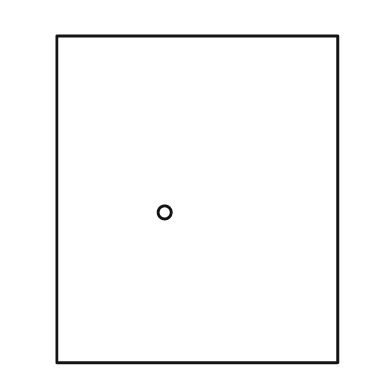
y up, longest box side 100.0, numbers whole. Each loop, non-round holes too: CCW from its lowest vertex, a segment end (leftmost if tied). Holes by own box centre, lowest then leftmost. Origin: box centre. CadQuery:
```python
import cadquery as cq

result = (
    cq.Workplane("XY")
    .moveTo(-43.0, -50.0)
    .lineTo(43.0, -50.0)
    .lineTo(43.0, 50.0)
    .lineTo(-43.0, 50.0)
    .close()
    .moveTo(-10.0, -4.0)
    .circle(2.0)
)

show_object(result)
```